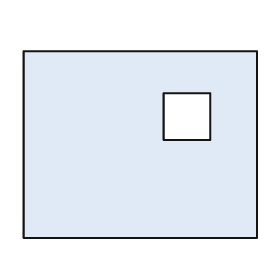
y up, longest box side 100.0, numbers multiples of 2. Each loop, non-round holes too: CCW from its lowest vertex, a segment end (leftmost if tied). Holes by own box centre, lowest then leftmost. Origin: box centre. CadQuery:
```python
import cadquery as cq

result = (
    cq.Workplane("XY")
    .moveTo(-50.0, -40.0)
    .lineTo(50.0, -40.0)
    .lineTo(50.0, 40.0)
    .lineTo(-50.0, 40.0)
    .close()
    .moveTo(10.0, 2.0)
    .lineTo(30.0, 2.0)
    .lineTo(30.0, 22.0)
    .lineTo(10.0, 22.0)
    .close()
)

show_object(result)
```